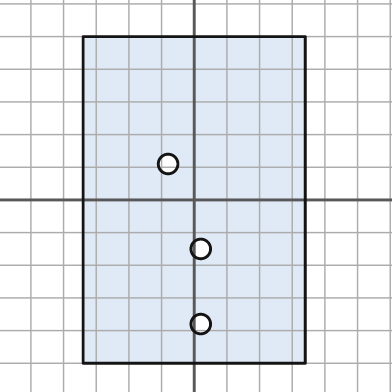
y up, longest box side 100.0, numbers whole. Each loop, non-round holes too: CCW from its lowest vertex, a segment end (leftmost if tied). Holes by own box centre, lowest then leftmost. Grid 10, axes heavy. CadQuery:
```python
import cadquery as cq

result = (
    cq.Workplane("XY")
    .moveTo(-34.0, -50.0)
    .lineTo(34.0, -50.0)
    .lineTo(34.0, 50.0)
    .lineTo(-34.0, 50.0)
    .close()
    .moveTo(2.0, -38.0)
    .circle(3.0)
    .moveTo(2.0, -15.0)
    .circle(3.0)
    .moveTo(-8.0, 11.0)
    .circle(3.0)
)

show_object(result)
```